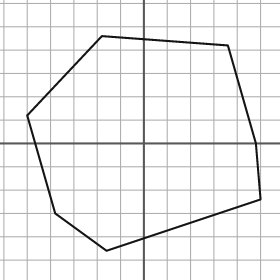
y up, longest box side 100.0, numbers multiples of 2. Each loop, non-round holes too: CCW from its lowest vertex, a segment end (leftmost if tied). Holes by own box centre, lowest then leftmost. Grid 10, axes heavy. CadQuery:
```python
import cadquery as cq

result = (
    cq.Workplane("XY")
    .moveTo(-16.0, -46.0)
    .lineTo(50.0, -24.0)
    .lineTo(48.0, 0.0)
    .lineTo(36.0, 42.0)
    .lineTo(-18.0, 46.0)
    .lineTo(-50.0, 12.0)
    .lineTo(-38.0, -30.0)
    .close()
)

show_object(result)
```